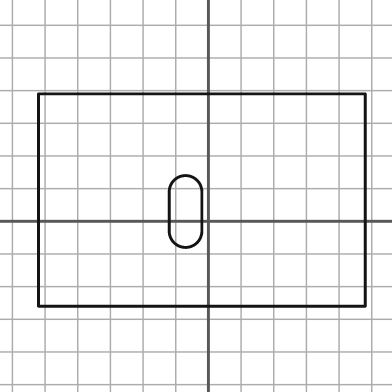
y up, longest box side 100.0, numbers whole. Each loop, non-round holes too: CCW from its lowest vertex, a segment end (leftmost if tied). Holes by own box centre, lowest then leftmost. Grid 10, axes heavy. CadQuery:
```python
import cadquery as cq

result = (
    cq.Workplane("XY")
    .moveTo(-52.0, -26.0)
    .lineTo(48.0, -26.0)
    .lineTo(48.0, 39.0)
    .lineTo(-52.0, 39.0)
    .close()
    .moveTo(-12.0, -3.0)
    .threePointArc((-7.0, -8.0), (-2.0, -3.0))
    .lineTo(-2.0, 9.0)
    .threePointArc((-7.0, 14.0), (-12.0, 9.0))
    .close()
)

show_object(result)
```